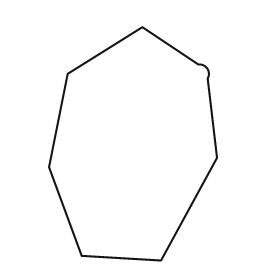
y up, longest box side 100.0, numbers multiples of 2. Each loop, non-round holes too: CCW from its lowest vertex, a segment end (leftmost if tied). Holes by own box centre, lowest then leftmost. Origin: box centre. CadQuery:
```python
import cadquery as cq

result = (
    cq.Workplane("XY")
    .moveTo(12.0, -50.0)
    .lineTo(36.0, -6.0)
    .lineTo(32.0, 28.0)
    .threePointArc((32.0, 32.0), (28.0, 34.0))
    .lineTo(4.0, 50.0)
    .lineTo(-28.0, 30.0)
    .lineTo(-36.0, -10.0)
    .lineTo(-22.0, -48.0)
    .close()
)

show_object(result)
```